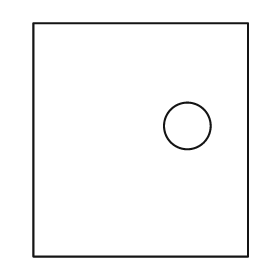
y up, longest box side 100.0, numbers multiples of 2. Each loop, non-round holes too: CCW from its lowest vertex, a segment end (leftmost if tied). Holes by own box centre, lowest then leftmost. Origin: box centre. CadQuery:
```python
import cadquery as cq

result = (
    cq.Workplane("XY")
    .moveTo(-46.0, -50.0)
    .lineTo(46.0, -50.0)
    .lineTo(46.0, 50.0)
    .lineTo(-46.0, 50.0)
    .close()
    .moveTo(20.0, 6.0)
    .circle(10.0)
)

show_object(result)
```